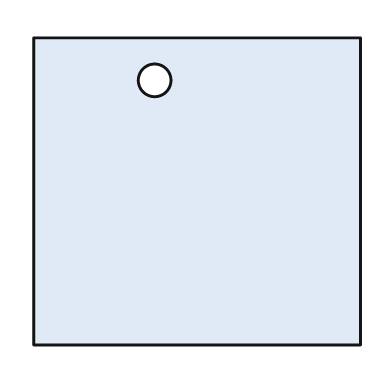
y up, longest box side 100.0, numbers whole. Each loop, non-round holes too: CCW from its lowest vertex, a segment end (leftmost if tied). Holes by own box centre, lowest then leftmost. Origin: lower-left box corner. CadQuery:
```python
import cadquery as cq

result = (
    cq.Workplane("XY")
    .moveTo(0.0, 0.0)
    .lineTo(100.0, 0.0)
    .lineTo(100.0, 94.0)
    .lineTo(0.0, 94.0)
    .close()
    .moveTo(37.0, 81.0)
    .circle(5.0)
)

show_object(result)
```